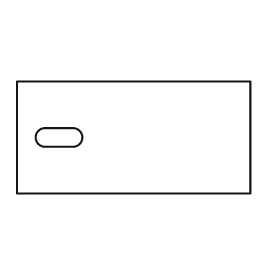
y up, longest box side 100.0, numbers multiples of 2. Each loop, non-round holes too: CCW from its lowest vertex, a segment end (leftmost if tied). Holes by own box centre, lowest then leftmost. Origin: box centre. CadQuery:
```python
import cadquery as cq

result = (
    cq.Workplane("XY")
    .moveTo(-50.0, -24.0)
    .lineTo(50.0, -24.0)
    .lineTo(50.0, 24.0)
    .lineTo(-50.0, 24.0)
    .close()
    .moveTo(-38.0, -4.0)
    .lineTo(-26.0, -4.0)
    .threePointArc((-22.0, 0.0), (-26.0, 4.0))
    .lineTo(-38.0, 4.0)
    .threePointArc((-42.0, 0.0), (-38.0, -4.0))
    .close()
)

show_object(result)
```